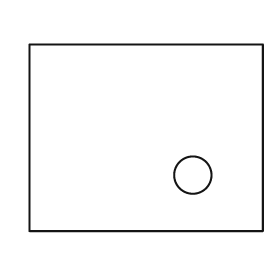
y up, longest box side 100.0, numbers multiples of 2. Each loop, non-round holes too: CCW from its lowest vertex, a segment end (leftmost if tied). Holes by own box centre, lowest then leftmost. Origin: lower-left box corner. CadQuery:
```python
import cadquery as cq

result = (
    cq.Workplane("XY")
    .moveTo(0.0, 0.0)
    .lineTo(100.0, 0.0)
    .lineTo(100.0, 80.0)
    .lineTo(0.0, 80.0)
    .close()
    .moveTo(70.0, 24.0)
    .circle(8.0)
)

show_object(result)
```